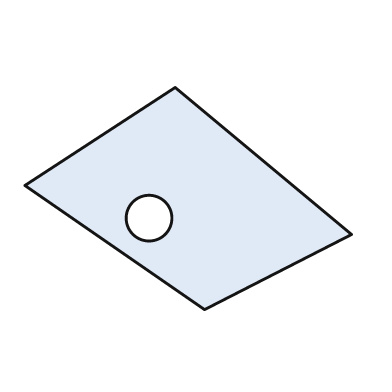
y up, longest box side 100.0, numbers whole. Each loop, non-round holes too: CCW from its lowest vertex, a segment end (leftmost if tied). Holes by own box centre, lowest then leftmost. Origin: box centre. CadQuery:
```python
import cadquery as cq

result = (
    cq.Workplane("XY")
    .moveTo(5.0, -34.0)
    .lineTo(50.0, -11.0)
    .lineTo(-4.0, 34.0)
    .lineTo(-50.0, 4.0)
    .close()
    .moveTo(-12.0, -6.0)
    .circle(7.0)
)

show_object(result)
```